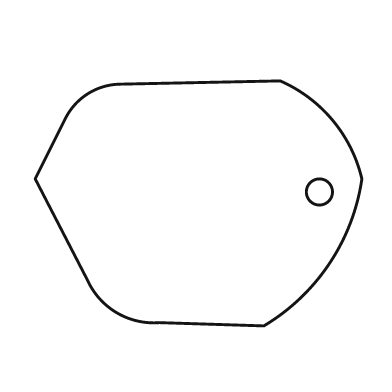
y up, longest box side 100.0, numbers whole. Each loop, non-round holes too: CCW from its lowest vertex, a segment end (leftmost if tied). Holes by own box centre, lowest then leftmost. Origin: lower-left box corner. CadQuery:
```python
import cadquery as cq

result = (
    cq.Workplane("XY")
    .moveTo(70.0, 0.0)
    .threePointArc((90.0, 19.0), (100.0, 45.0))
    .threePointArc((91.0, 63.0), (75.0, 75.0))
    .lineTo(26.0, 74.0)
    .threePointArc((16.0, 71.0), (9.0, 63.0))
    .lineTo(0.0, 45.0)
    .lineTo(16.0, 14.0)
    .threePointArc((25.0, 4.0), (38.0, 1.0))
    .close()
    .moveTo(87.0, 41.0)
    .circle(4.0)
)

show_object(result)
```